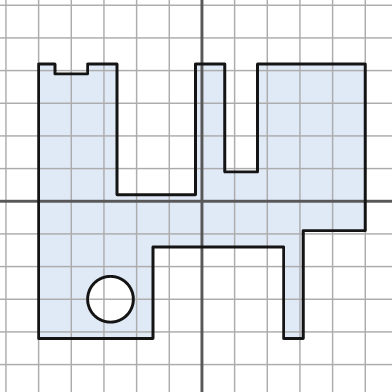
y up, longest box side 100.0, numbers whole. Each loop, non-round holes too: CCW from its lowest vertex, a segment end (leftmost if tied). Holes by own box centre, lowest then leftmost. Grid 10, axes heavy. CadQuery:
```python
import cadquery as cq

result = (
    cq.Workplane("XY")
    .moveTo(-50.0, -42.0)
    .lineTo(-15.0, -42.0)
    .lineTo(-15.0, -14.0)
    .lineTo(25.0, -14.0)
    .lineTo(25.0, -42.0)
    .lineTo(31.0, -42.0)
    .lineTo(31.0, -9.0)
    .lineTo(50.0, -9.0)
    .lineTo(50.0, 42.0)
    .lineTo(17.0, 42.0)
    .lineTo(17.0, 9.0)
    .lineTo(7.0, 9.0)
    .lineTo(7.0, 42.0)
    .lineTo(-2.0, 42.0)
    .lineTo(-2.0, 2.0)
    .lineTo(-26.0, 2.0)
    .lineTo(-26.0, 42.0)
    .lineTo(-35.0, 42.0)
    .lineTo(-35.0, 39.0)
    .lineTo(-45.0, 39.0)
    .lineTo(-45.0, 42.0)
    .lineTo(-50.0, 42.0)
    .close()
    .moveTo(-28.0, -30.0)
    .circle(7.0)
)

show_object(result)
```